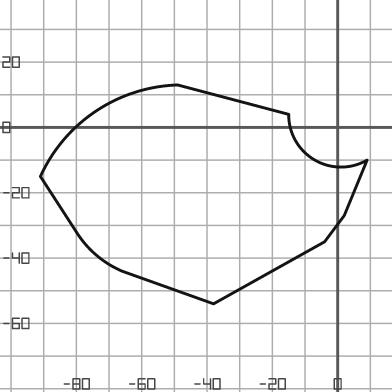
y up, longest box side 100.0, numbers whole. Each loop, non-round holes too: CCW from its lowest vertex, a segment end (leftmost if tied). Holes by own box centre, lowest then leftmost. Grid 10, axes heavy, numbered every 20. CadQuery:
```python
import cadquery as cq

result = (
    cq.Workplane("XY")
    .moveTo(-38.0, -54.0)
    .lineTo(-4.0, -35.0)
    .lineTo(2.0, -27.0)
    .lineTo(9.0, -10.0)
    .threePointArc((-7.0, -10.0), (-15.0, 4.0))
    .lineTo(-49.0, 13.0)
    .threePointArc((-74.0, 5.0), (-91.0, -15.0))
    .lineTo(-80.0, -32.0)
    .threePointArc((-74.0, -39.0), (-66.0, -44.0))
    .close()
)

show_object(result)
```